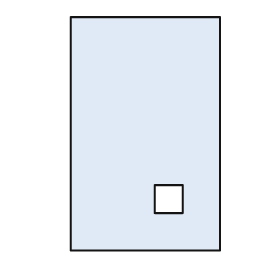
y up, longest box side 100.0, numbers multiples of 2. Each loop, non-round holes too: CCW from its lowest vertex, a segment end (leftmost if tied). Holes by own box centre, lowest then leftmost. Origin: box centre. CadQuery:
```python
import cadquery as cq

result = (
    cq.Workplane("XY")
    .moveTo(-32.0, -50.0)
    .lineTo(32.0, -50.0)
    .lineTo(32.0, 50.0)
    .lineTo(-32.0, 50.0)
    .close()
    .moveTo(4.0, -34.0)
    .lineTo(16.0, -34.0)
    .lineTo(16.0, -22.0)
    .lineTo(4.0, -22.0)
    .close()
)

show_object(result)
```